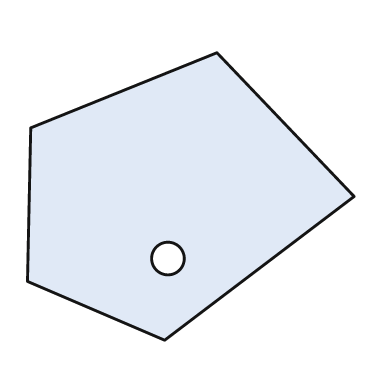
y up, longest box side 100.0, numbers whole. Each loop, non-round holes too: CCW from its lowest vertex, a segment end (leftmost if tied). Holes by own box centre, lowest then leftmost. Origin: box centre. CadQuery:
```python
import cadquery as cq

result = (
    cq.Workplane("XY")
    .moveTo(-8.0, -44.0)
    .lineTo(50.0, 0.0)
    .lineTo(8.0, 44.0)
    .lineTo(-49.0, 21.0)
    .lineTo(-50.0, -26.0)
    .close()
    .moveTo(-7.0, -19.0)
    .circle(5.0)
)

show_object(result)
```